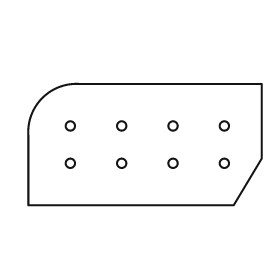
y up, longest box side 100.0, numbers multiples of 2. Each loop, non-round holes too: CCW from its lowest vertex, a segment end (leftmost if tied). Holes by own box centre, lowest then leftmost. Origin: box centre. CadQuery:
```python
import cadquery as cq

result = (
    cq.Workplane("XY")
    .moveTo(-50.0, -26.0)
    .lineTo(38.0, -26.0)
    .lineTo(50.0, -6.0)
    .lineTo(50.0, 26.0)
    .lineTo(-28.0, 26.0)
    .threePointArc((-44.0, 20.0), (-50.0, 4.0))
    .close()
    .moveTo(-32.0, -8.0)
    .circle(2.0)
    .moveTo(-10.0, -8.0)
    .circle(2.0)
    .moveTo(12.0, -8.0)
    .circle(2.0)
    .moveTo(34.0, -8.0)
    .circle(2.0)
    .moveTo(-32.0, 8.0)
    .circle(2.0)
    .moveTo(-10.0, 8.0)
    .circle(2.0)
    .moveTo(12.0, 8.0)
    .circle(2.0)
    .moveTo(34.0, 8.0)
    .circle(2.0)
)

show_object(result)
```